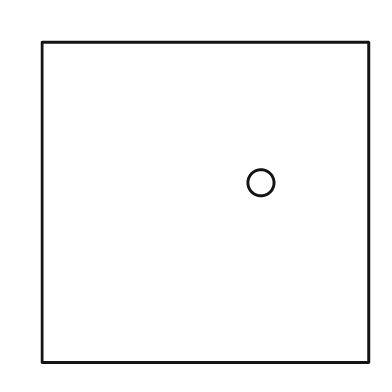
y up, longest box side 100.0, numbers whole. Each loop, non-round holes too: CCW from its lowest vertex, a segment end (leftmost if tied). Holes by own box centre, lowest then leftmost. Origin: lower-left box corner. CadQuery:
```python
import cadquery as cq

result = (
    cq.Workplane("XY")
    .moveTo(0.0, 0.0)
    .lineTo(100.0, 0.0)
    .lineTo(100.0, 98.0)
    .lineTo(0.0, 98.0)
    .close()
    .moveTo(67.0, 55.0)
    .circle(4.0)
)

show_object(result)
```